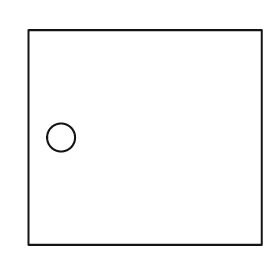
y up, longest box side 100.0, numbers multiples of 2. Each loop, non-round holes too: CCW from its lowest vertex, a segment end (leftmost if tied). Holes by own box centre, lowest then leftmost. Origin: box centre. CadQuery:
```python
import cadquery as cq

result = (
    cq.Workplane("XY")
    .moveTo(-50.0, -46.0)
    .lineTo(50.0, -46.0)
    .lineTo(50.0, 46.0)
    .lineTo(-50.0, 46.0)
    .close()
    .moveTo(-36.0, 0.0)
    .circle(6.0)
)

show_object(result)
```